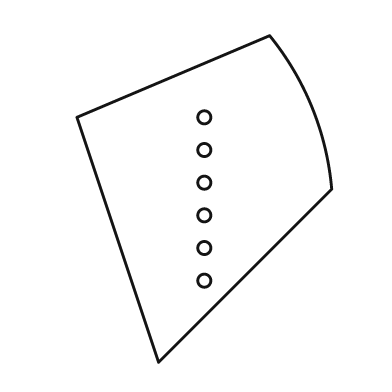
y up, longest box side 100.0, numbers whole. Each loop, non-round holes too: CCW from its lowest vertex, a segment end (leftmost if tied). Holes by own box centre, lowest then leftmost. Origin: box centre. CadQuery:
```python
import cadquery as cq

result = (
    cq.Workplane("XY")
    .moveTo(-14.0, -50.0)
    .lineTo(39.0, 3.0)
    .threePointArc((33.0, 28.0), (20.0, 50.0))
    .lineTo(-39.0, 25.0)
    .close()
    .moveTo(0.0, -25.0)
    .circle(2.0)
    .moveTo(0.0, -15.0)
    .circle(2.0)
    .moveTo(0.0, -5.0)
    .circle(2.0)
    .moveTo(0.0, 5.0)
    .circle(2.0)
    .moveTo(0.0, 15.0)
    .circle(2.0)
    .moveTo(0.0, 25.0)
    .circle(2.0)
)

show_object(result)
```